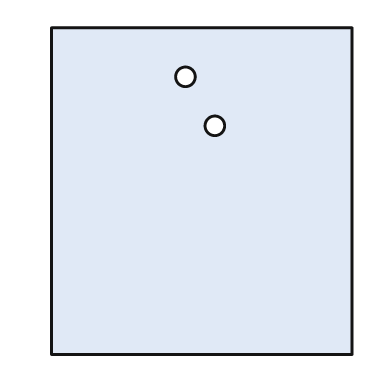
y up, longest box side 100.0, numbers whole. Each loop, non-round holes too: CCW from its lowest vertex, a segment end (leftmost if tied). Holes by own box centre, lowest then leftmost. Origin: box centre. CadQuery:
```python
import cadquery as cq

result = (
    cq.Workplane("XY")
    .moveTo(-46.0, -50.0)
    .lineTo(46.0, -50.0)
    .lineTo(46.0, 50.0)
    .lineTo(-46.0, 50.0)
    .close()
    .moveTo(4.0, 20.0)
    .circle(3.0)
    .moveTo(-5.0, 35.0)
    .circle(3.0)
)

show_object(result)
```